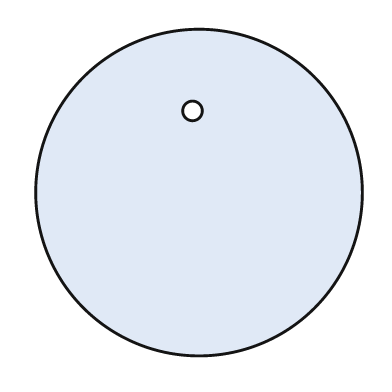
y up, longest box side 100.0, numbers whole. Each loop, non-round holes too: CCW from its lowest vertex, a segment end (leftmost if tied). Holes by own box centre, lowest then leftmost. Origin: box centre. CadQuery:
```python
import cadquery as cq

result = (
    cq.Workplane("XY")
    .moveTo(0.0, 0.0)
    .circle(50.0)
    .moveTo(-2.0, 25.0)
    .circle(3.0)
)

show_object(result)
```